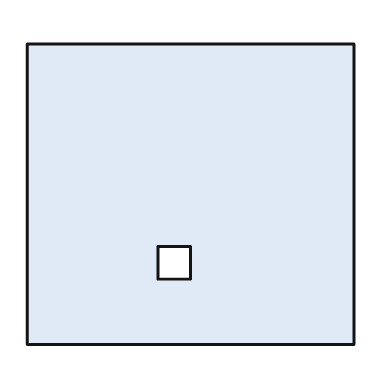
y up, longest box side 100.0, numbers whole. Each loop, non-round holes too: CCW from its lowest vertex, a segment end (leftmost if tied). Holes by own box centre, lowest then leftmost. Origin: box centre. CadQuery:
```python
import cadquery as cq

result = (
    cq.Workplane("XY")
    .moveTo(-50.0, -46.0)
    .lineTo(50.0, -46.0)
    .lineTo(50.0, 46.0)
    .lineTo(-50.0, 46.0)
    .close()
    .moveTo(-10.0, -26.0)
    .lineTo(0.0, -26.0)
    .lineTo(0.0, -16.0)
    .lineTo(-10.0, -16.0)
    .close()
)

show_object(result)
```